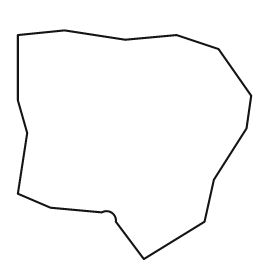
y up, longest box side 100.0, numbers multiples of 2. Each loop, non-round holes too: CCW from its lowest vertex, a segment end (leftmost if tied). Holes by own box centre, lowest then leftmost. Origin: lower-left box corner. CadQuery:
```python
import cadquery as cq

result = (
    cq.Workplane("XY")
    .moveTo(54.0, 0.0)
    .lineTo(80.0, 16.0)
    .lineTo(84.0, 34.0)
    .lineTo(98.0, 56.0)
    .lineTo(100.0, 70.0)
    .lineTo(86.0, 90.0)
    .lineTo(68.0, 96.0)
    .lineTo(46.0, 94.0)
    .lineTo(20.0, 98.0)
    .lineTo(0.0, 96.0)
    .lineTo(0.0, 68.0)
    .lineTo(4.0, 54.0)
    .lineTo(0.0, 28.0)
    .lineTo(14.0, 22.0)
    .lineTo(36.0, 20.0)
    .threePointArc((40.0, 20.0), (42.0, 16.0))
    .close()
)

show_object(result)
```